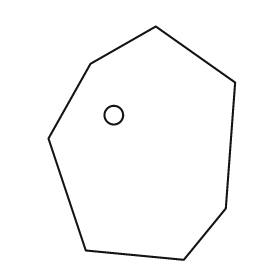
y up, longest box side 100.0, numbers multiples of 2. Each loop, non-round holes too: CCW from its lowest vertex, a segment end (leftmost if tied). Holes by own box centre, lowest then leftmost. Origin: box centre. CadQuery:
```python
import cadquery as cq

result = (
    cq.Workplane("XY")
    .moveTo(18.0, -50.0)
    .lineTo(36.0, -28.0)
    .lineTo(40.0, 26.0)
    .lineTo(6.0, 50.0)
    .lineTo(-22.0, 34.0)
    .lineTo(-40.0, 2.0)
    .lineTo(-24.0, -46.0)
    .close()
    .moveTo(-12.0, 12.0)
    .circle(4.0)
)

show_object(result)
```